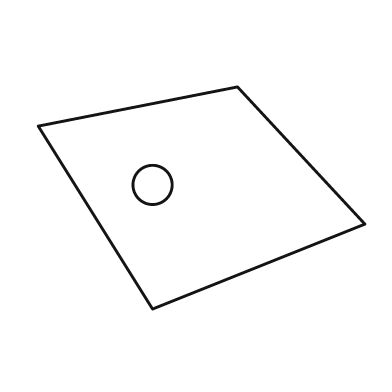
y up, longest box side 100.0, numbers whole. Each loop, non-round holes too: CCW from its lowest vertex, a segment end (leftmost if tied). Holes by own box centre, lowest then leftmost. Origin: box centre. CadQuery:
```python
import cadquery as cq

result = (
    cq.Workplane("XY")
    .moveTo(-15.0, -34.0)
    .lineTo(50.0, -8.0)
    .lineTo(11.0, 34.0)
    .lineTo(-50.0, 22.0)
    .close()
    .moveTo(-15.0, 4.0)
    .circle(6.0)
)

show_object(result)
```